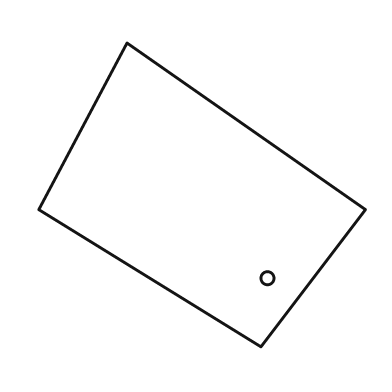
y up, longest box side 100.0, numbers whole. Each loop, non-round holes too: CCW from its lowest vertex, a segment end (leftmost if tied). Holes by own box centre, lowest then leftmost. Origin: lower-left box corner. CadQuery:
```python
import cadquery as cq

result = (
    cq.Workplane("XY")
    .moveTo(68.0, 0.0)
    .lineTo(100.0, 42.0)
    .lineTo(27.0, 93.0)
    .lineTo(0.0, 42.0)
    .close()
    .moveTo(70.0, 21.0)
    .circle(2.0)
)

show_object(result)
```